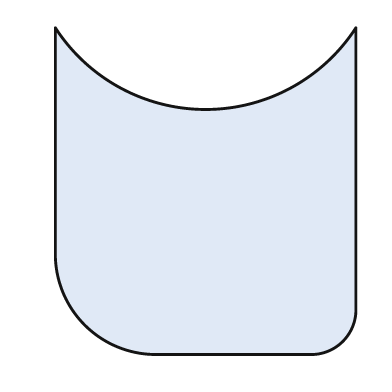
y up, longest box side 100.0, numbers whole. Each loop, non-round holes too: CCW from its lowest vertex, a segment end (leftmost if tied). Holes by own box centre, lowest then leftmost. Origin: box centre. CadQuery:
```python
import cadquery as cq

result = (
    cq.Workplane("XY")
    .moveTo(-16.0, -50.0)
    .lineTo(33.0, -50.0)
    .threePointArc((42.0, -46.0), (46.0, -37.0))
    .lineTo(46.0, 50.0)
    .threePointArc((0.0, 25.0), (-46.0, 50.0))
    .lineTo(-46.0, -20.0)
    .threePointArc((-37.0, -41.0), (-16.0, -50.0))
    .close()
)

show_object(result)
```